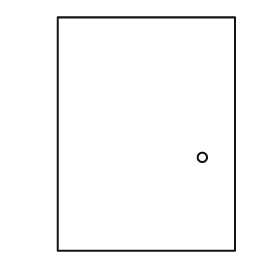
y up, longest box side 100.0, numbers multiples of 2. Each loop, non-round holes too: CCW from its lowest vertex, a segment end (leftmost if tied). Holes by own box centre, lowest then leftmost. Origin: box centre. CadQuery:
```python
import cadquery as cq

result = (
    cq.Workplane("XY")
    .moveTo(-38.0, -50.0)
    .lineTo(38.0, -50.0)
    .lineTo(38.0, 50.0)
    .lineTo(-38.0, 50.0)
    .close()
    .moveTo(24.0, -10.0)
    .circle(2.0)
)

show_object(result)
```